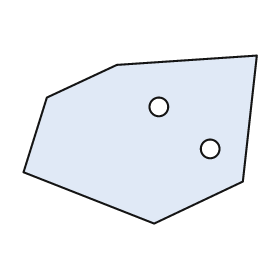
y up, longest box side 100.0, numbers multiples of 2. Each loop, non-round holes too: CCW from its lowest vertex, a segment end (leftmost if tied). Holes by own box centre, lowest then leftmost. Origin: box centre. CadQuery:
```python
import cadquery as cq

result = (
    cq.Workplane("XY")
    .moveTo(6.0, -36.0)
    .lineTo(44.0, -18.0)
    .lineTo(50.0, 36.0)
    .lineTo(-10.0, 32.0)
    .lineTo(-40.0, 18.0)
    .lineTo(-50.0, -14.0)
    .close()
    .moveTo(30.0, -4.0)
    .circle(4.0)
    .moveTo(8.0, 14.0)
    .circle(4.0)
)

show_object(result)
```